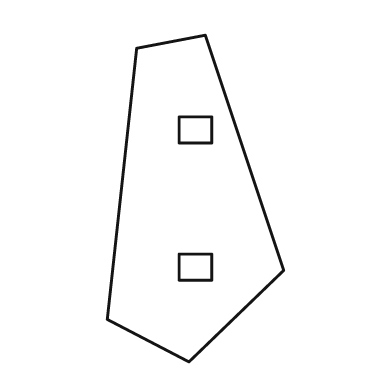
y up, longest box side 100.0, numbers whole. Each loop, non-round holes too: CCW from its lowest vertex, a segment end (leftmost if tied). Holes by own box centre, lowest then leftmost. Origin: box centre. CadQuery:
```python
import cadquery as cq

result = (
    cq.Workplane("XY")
    .moveTo(-2.0, -50.0)
    .lineTo(27.0, -22.0)
    .lineTo(3.0, 50.0)
    .lineTo(-18.0, 46.0)
    .lineTo(-27.0, -37.0)
    .close()
    .moveTo(-5.0, -25.0)
    .lineTo(5.0, -25.0)
    .lineTo(5.0, -17.0)
    .lineTo(-5.0, -17.0)
    .close()
    .moveTo(-5.0, 17.0)
    .lineTo(5.0, 17.0)
    .lineTo(5.0, 25.0)
    .lineTo(-5.0, 25.0)
    .close()
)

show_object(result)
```